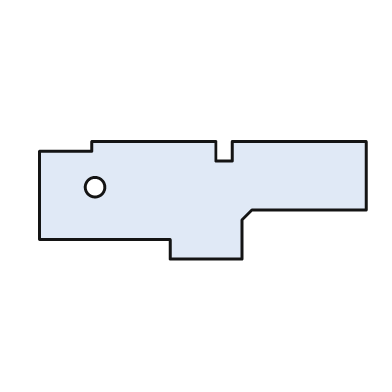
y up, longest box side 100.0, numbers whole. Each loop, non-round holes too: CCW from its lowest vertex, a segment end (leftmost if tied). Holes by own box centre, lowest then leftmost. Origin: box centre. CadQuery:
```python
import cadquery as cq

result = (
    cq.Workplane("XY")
    .moveTo(-10.0, -18.0)
    .lineTo(12.0, -18.0)
    .lineTo(12.0, -6.0)
    .lineTo(15.0, -3.0)
    .lineTo(50.0, -3.0)
    .lineTo(50.0, 18.0)
    .lineTo(9.0, 18.0)
    .lineTo(9.0, 12.0)
    .lineTo(4.0, 12.0)
    .lineTo(4.0, 18.0)
    .lineTo(-34.0, 18.0)
    .lineTo(-34.0, 15.0)
    .lineTo(-50.0, 15.0)
    .lineTo(-50.0, -12.0)
    .lineTo(-10.0, -12.0)
    .close()
    .moveTo(-33.0, 4.0)
    .circle(3.0)
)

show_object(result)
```